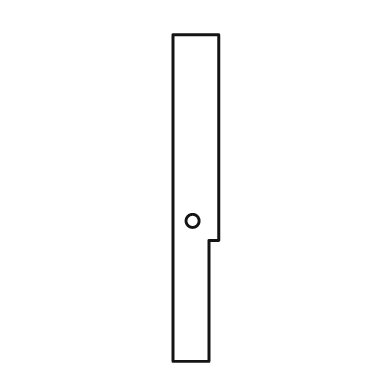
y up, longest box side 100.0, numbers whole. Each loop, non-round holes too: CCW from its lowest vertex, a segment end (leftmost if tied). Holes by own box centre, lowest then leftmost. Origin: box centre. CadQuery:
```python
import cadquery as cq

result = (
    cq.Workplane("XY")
    .moveTo(-7.0, -50.0)
    .lineTo(4.0, -50.0)
    .lineTo(4.0, -13.0)
    .lineTo(7.0, -13.0)
    .lineTo(7.0, 50.0)
    .lineTo(-7.0, 50.0)
    .close()
    .moveTo(-1.0, -7.0)
    .circle(2.0)
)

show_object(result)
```